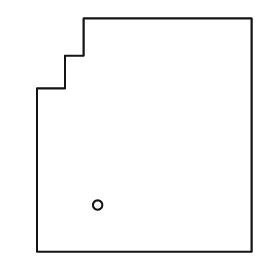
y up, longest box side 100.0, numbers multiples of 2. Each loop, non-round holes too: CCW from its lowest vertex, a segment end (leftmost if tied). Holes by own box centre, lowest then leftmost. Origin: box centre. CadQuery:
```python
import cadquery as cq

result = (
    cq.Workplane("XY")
    .moveTo(-46.0, -50.0)
    .lineTo(46.0, -50.0)
    .lineTo(46.0, 50.0)
    .lineTo(-26.0, 50.0)
    .lineTo(-26.0, 34.0)
    .lineTo(-34.0, 34.0)
    .lineTo(-34.0, 20.0)
    .lineTo(-46.0, 20.0)
    .close()
    .moveTo(-20.0, -30.0)
    .circle(2.0)
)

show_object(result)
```